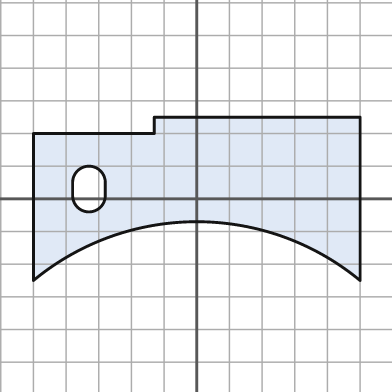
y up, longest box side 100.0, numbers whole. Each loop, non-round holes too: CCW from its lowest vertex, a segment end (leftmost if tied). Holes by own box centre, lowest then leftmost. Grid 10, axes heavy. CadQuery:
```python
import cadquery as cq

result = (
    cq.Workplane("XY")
    .moveTo(-50.0, -25.0)
    .threePointArc((0.0, -7.0), (50.0, -25.0))
    .lineTo(50.0, 25.0)
    .lineTo(-13.0, 25.0)
    .lineTo(-13.0, 20.0)
    .lineTo(-50.0, 20.0)
    .close()
    .moveTo(-38.0, 1.0)
    .threePointArc((-33.0, -4.0), (-28.0, 1.0))
    .lineTo(-28.0, 5.0)
    .threePointArc((-33.0, 10.0), (-38.0, 5.0))
    .close()
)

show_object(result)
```